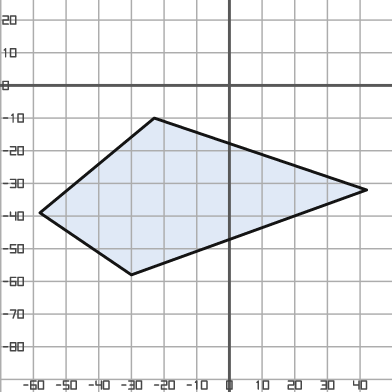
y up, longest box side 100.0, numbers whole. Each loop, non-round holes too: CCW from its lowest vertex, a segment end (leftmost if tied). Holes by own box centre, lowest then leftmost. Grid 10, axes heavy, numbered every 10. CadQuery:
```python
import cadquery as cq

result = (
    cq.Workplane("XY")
    .moveTo(-30.0, -58.0)
    .lineTo(42.0, -32.0)
    .lineTo(-23.0, -10.0)
    .lineTo(-58.0, -39.0)
    .close()
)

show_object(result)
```